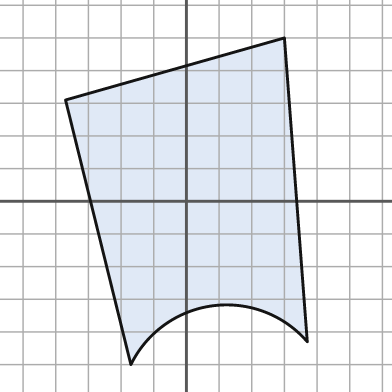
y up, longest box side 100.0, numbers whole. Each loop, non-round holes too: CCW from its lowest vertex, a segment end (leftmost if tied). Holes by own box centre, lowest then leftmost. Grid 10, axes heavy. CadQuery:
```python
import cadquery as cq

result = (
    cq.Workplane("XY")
    .moveTo(-17.0, -50.0)
    .threePointArc((8.0, -32.0), (37.0, -43.0))
    .lineTo(30.0, 50.0)
    .lineTo(-37.0, 31.0)
    .close()
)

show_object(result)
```